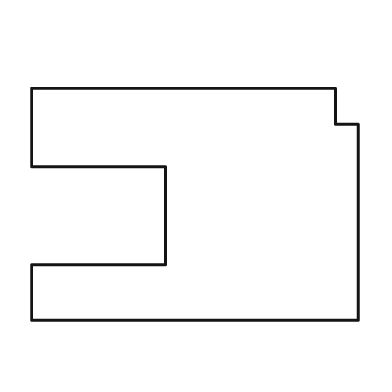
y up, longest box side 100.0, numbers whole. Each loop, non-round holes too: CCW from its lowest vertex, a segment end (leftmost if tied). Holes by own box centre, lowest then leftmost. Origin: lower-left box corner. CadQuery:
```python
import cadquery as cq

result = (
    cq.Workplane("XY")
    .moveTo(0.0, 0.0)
    .lineTo(100.0, 0.0)
    .lineTo(100.0, 60.0)
    .lineTo(93.0, 60.0)
    .lineTo(93.0, 71.0)
    .lineTo(0.0, 71.0)
    .lineTo(0.0, 47.0)
    .lineTo(41.0, 47.0)
    .lineTo(41.0, 17.0)
    .lineTo(0.0, 17.0)
    .close()
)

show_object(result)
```